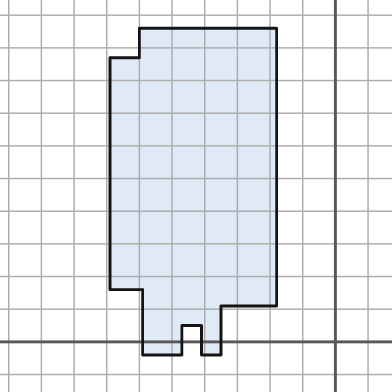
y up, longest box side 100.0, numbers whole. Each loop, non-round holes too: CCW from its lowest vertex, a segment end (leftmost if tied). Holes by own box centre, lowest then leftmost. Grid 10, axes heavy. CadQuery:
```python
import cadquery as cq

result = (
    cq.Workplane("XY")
    .moveTo(-59.0, -4.0)
    .lineTo(-47.0, -4.0)
    .lineTo(-47.0, 5.0)
    .lineTo(-41.0, 5.0)
    .lineTo(-41.0, -4.0)
    .lineTo(-35.0, -4.0)
    .lineTo(-35.0, 11.0)
    .lineTo(-18.0, 11.0)
    .lineTo(-18.0, 96.0)
    .lineTo(-60.0, 96.0)
    .lineTo(-60.0, 87.0)
    .lineTo(-69.0, 87.0)
    .lineTo(-69.0, 16.0)
    .lineTo(-59.0, 16.0)
    .close()
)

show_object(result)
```